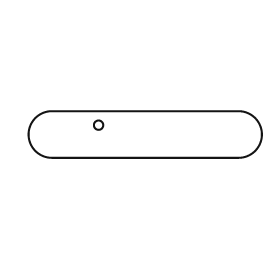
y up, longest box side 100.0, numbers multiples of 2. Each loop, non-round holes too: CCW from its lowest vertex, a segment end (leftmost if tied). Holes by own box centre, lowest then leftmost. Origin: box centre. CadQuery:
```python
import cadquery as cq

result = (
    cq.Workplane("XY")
    .moveTo(-40.0, -10.0)
    .lineTo(40.0, -10.0)
    .threePointArc((50.0, 0.0), (40.0, 10.0))
    .lineTo(-40.0, 10.0)
    .threePointArc((-50.0, 0.0), (-40.0, -10.0))
    .close()
    .moveTo(-20.0, 4.0)
    .circle(2.0)
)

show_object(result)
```